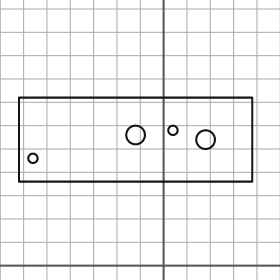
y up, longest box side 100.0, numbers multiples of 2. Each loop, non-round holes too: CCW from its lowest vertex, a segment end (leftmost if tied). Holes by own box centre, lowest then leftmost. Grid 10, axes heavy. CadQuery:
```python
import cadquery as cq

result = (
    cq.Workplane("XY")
    .moveTo(-62.0, 36.0)
    .lineTo(38.0, 36.0)
    .lineTo(38.0, 72.0)
    .lineTo(-62.0, 72.0)
    .close()
    .moveTo(-56.0, 46.0)
    .circle(2.0)
    .moveTo(18.0, 54.0)
    .circle(4.0)
    .moveTo(-12.0, 56.0)
    .circle(4.0)
    .moveTo(4.0, 58.0)
    .circle(2.0)
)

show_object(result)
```